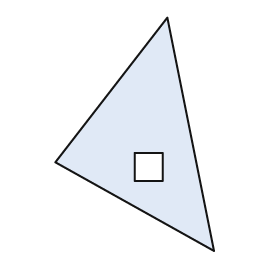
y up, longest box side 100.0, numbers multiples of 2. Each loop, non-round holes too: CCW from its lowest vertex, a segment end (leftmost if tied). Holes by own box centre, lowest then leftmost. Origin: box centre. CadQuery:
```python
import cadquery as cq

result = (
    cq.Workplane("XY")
    .moveTo(34.0, -50.0)
    .lineTo(14.0, 50.0)
    .lineTo(-34.0, -12.0)
    .close()
    .moveTo(0.0, -20.0)
    .lineTo(12.0, -20.0)
    .lineTo(12.0, -8.0)
    .lineTo(0.0, -8.0)
    .close()
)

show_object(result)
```